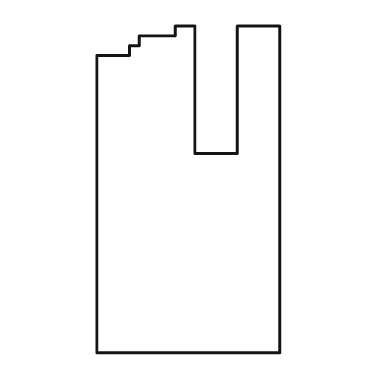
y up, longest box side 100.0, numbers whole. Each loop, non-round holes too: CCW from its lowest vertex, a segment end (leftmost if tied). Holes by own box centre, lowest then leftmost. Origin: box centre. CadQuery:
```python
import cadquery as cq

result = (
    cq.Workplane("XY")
    .moveTo(-28.0, -50.0)
    .lineTo(28.0, -50.0)
    .lineTo(28.0, 50.0)
    .lineTo(15.0, 50.0)
    .lineTo(15.0, 11.0)
    .lineTo(2.0, 11.0)
    .lineTo(2.0, 50.0)
    .lineTo(-4.0, 50.0)
    .lineTo(-4.0, 47.0)
    .lineTo(-15.0, 47.0)
    .lineTo(-15.0, 44.0)
    .lineTo(-18.0, 44.0)
    .lineTo(-18.0, 41.0)
    .lineTo(-28.0, 41.0)
    .close()
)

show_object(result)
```